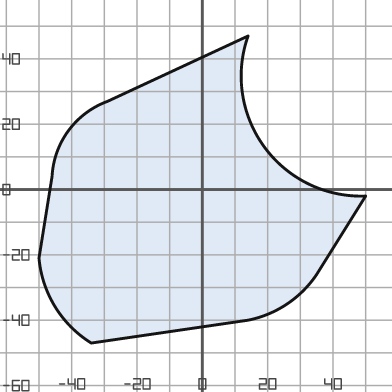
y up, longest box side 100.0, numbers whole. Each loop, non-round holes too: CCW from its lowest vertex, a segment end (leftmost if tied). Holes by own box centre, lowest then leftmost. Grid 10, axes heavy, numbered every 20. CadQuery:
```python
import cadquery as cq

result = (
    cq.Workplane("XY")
    .moveTo(-34.0, -47.0)
    .lineTo(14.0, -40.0)
    .threePointArc((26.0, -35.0), (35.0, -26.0))
    .lineTo(50.0, -2.0)
    .threePointArc((19.0, 13.0), (14.0, 47.0))
    .lineTo(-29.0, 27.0)
    .threePointArc((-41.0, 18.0), (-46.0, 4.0))
    .lineTo(-50.0, -21.0)
    .threePointArc((-45.0, -36.0), (-34.0, -47.0))
    .close()
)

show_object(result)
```